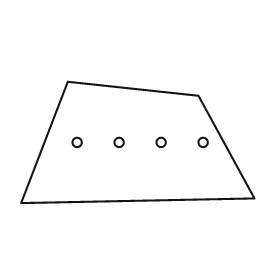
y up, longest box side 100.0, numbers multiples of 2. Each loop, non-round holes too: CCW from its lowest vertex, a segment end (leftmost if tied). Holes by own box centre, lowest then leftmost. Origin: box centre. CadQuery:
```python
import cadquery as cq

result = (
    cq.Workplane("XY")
    .moveTo(-50.0, -26.0)
    .lineTo(50.0, -24.0)
    .lineTo(26.0, 20.0)
    .lineTo(-30.0, 26.0)
    .close()
    .moveTo(-26.0, 0.0)
    .circle(2.0)
    .moveTo(-8.0, 0.0)
    .circle(2.0)
    .moveTo(10.0, 0.0)
    .circle(2.0)
    .moveTo(28.0, 0.0)
    .circle(2.0)
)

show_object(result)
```